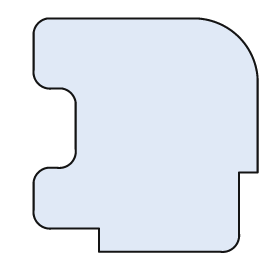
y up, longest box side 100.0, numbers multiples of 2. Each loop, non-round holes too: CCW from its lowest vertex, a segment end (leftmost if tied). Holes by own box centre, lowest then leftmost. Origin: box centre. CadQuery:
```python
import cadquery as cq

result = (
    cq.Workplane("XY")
    .moveTo(-20.0, -50.0)
    .lineTo(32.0, -50.0)
    .threePointArc((38.0, -48.0), (40.0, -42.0))
    .lineTo(40.0, -16.0)
    .lineTo(48.0, -16.0)
    .lineTo(48.0, 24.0)
    .threePointArc((40.0, 42.0), (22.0, 50.0))
    .lineTo(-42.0, 50.0)
    .threePointArc((-46.0, 48.0), (-48.0, 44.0))
    .lineTo(-48.0, 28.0)
    .threePointArc((-46.0, 22.0), (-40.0, 20.0))
    .lineTo(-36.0, 20.0)
    .threePointArc((-32.0, 18.0), (-30.0, 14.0))
    .lineTo(-30.0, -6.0)
    .threePointArc((-32.0, -12.0), (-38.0, -14.0))
    .lineTo(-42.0, -14.0)
    .threePointArc((-46.0, -16.0), (-48.0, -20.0))
    .lineTo(-48.0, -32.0)
    .threePointArc((-46.0, -38.0), (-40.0, -40.0))
    .lineTo(-20.0, -40.0)
    .close()
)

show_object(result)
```